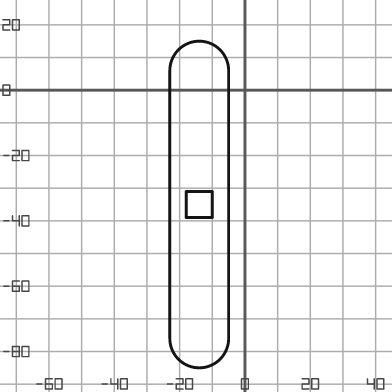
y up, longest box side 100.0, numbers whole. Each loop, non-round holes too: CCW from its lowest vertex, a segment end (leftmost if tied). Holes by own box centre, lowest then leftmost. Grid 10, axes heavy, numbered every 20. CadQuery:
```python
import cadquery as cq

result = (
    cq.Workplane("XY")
    .moveTo(-23.0, -76.0)
    .threePointArc((-14.0, -85.0), (-5.0, -76.0))
    .lineTo(-5.0, 6.0)
    .threePointArc((-14.0, 15.0), (-23.0, 6.0))
    .close()
    .moveTo(-18.0, -39.0)
    .lineTo(-10.0, -39.0)
    .lineTo(-10.0, -31.0)
    .lineTo(-18.0, -31.0)
    .close()
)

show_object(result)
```